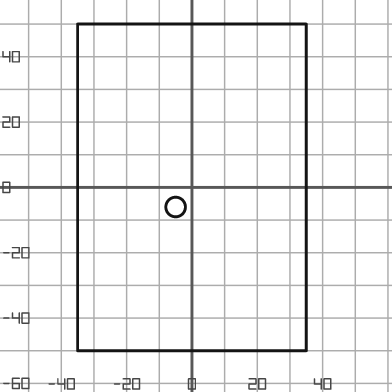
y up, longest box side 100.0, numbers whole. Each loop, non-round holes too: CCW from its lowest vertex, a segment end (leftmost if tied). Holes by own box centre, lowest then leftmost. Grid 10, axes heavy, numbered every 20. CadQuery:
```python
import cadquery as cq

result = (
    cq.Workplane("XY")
    .moveTo(-35.0, -50.0)
    .lineTo(35.0, -50.0)
    .lineTo(35.0, 50.0)
    .lineTo(-35.0, 50.0)
    .close()
    .moveTo(-5.0, -6.0)
    .circle(3.0)
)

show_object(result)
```